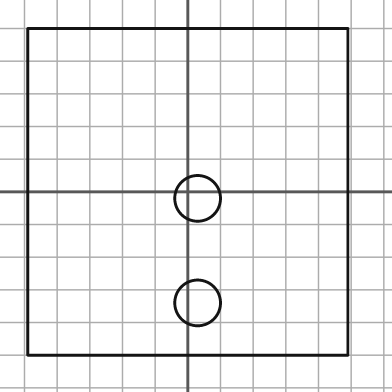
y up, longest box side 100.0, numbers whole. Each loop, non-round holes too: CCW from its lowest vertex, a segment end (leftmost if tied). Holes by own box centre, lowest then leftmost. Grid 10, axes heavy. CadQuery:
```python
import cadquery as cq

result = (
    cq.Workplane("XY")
    .moveTo(-49.0, -50.0)
    .lineTo(49.0, -50.0)
    .lineTo(49.0, 50.0)
    .lineTo(-49.0, 50.0)
    .close()
    .moveTo(3.0, -34.0)
    .circle(7.0)
    .moveTo(3.0, -2.0)
    .circle(7.0)
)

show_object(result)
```